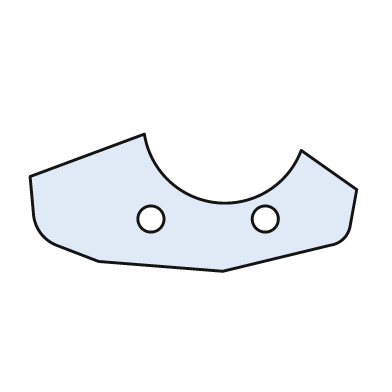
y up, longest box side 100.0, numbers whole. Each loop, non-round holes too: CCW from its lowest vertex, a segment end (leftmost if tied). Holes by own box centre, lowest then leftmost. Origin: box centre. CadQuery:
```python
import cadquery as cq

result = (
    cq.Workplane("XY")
    .moveTo(9.0, -21.0)
    .lineTo(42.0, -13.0)
    .threePointArc((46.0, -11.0), (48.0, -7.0))
    .lineTo(50.0, 4.0)
    .lineTo(33.0, 16.0)
    .threePointArc((7.0, 0.0), (-15.0, 21.0))
    .lineTo(-50.0, 8.0)
    .lineTo(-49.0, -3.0)
    .threePointArc((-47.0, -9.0), (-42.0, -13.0))
    .lineTo(-29.0, -18.0)
    .close()
    .moveTo(-13.0, -5.0)
    .circle(4.0)
    .moveTo(22.0, -5.0)
    .circle(4.0)
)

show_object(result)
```